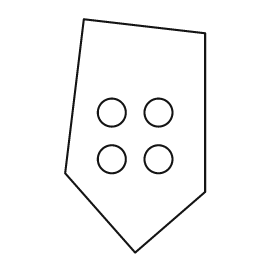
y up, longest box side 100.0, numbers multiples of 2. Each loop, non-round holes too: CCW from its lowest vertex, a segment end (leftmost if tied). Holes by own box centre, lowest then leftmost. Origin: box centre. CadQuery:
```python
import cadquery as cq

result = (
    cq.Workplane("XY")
    .moveTo(0.0, -50.0)
    .lineTo(30.0, -24.0)
    .lineTo(30.0, 44.0)
    .lineTo(-22.0, 50.0)
    .lineTo(-30.0, -16.0)
    .close()
    .moveTo(-10.0, -10.0)
    .circle(6.0)
    .moveTo(10.0, -10.0)
    .circle(6.0)
    .moveTo(-10.0, 10.0)
    .circle(6.0)
    .moveTo(10.0, 10.0)
    .circle(6.0)
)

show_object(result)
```